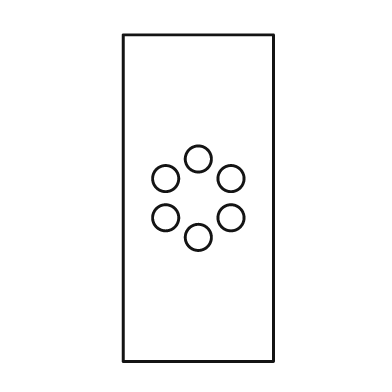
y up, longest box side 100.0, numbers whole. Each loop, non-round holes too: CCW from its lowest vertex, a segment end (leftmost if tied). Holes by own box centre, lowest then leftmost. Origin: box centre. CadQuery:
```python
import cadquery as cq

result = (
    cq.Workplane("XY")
    .moveTo(-23.0, -50.0)
    .lineTo(23.0, -50.0)
    .lineTo(23.0, 50.0)
    .lineTo(-23.0, 50.0)
    .close()
    .moveTo(0.0, -12.0)
    .circle(4.0)
    .moveTo(-10.0, -6.0)
    .circle(4.0)
    .moveTo(10.0, -6.0)
    .circle(4.0)
    .moveTo(-10.0, 6.0)
    .circle(4.0)
    .moveTo(10.0, 6.0)
    .circle(4.0)
    .moveTo(0.0, 12.0)
    .circle(4.0)
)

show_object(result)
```